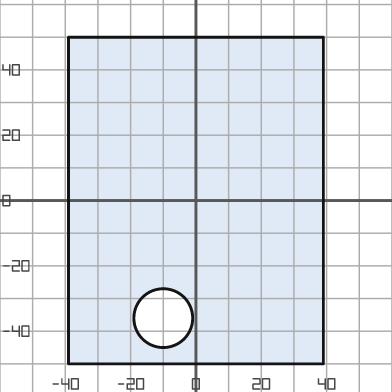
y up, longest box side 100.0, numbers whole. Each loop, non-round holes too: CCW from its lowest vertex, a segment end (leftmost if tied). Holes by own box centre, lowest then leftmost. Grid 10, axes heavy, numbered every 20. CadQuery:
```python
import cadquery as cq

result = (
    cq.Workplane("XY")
    .moveTo(-39.0, -50.0)
    .lineTo(39.0, -50.0)
    .lineTo(39.0, 50.0)
    .lineTo(-39.0, 50.0)
    .close()
    .moveTo(-10.0, -36.0)
    .circle(9.0)
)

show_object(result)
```